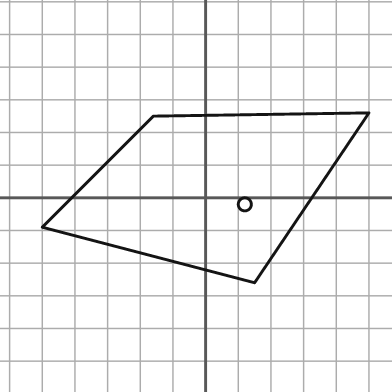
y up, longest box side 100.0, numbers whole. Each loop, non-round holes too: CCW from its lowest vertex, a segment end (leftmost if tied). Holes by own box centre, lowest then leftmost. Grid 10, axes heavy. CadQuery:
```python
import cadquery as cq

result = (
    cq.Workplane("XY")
    .moveTo(15.0, -26.0)
    .lineTo(50.0, 26.0)
    .lineTo(-16.0, 25.0)
    .lineTo(-50.0, -9.0)
    .close()
    .moveTo(12.0, -2.0)
    .circle(2.0)
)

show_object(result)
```